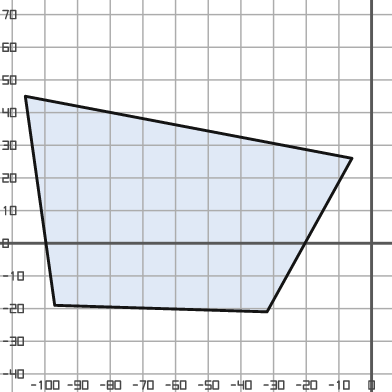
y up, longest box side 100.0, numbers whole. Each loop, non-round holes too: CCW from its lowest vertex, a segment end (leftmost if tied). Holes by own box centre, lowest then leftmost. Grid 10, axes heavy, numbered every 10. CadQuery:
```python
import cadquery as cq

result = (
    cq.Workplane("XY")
    .moveTo(-32.0, -21.0)
    .lineTo(-6.0, 26.0)
    .lineTo(-106.0, 45.0)
    .lineTo(-97.0, -19.0)
    .close()
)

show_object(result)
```